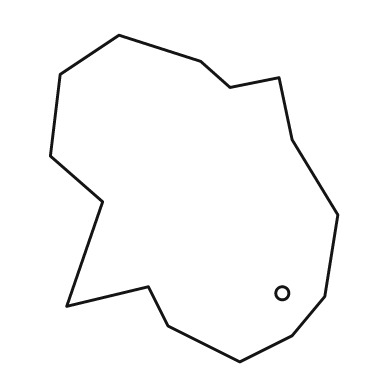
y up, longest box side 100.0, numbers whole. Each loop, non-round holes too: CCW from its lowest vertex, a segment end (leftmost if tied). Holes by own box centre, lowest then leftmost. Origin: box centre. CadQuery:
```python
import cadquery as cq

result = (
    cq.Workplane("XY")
    .moveTo(14.0, -50.0)
    .lineTo(30.0, -42.0)
    .lineTo(40.0, -30.0)
    .lineTo(44.0, -5.0)
    .lineTo(30.0, 18.0)
    .lineTo(26.0, 37.0)
    .lineTo(11.0, 34.0)
    .lineTo(2.0, 42.0)
    .lineTo(-23.0, 50.0)
    .lineTo(-41.0, 38.0)
    .lineTo(-44.0, 13.0)
    .lineTo(-28.0, -1.0)
    .lineTo(-39.0, -33.0)
    .lineTo(-14.0, -27.0)
    .lineTo(-8.0, -39.0)
    .close()
    .moveTo(27.0, -29.0)
    .circle(2.0)
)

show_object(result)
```